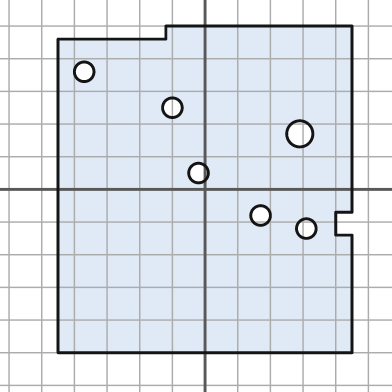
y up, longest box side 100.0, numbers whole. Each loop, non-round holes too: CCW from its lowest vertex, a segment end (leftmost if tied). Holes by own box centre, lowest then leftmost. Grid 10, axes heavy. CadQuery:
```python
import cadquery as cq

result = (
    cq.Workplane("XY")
    .moveTo(-45.0, -50.0)
    .lineTo(45.0, -50.0)
    .lineTo(45.0, -14.0)
    .lineTo(40.0, -14.0)
    .lineTo(40.0, -7.0)
    .lineTo(45.0, -7.0)
    .lineTo(45.0, 50.0)
    .lineTo(-12.0, 50.0)
    .lineTo(-12.0, 46.0)
    .lineTo(-45.0, 46.0)
    .close()
    .moveTo(31.0, -12.0)
    .circle(3.0)
    .moveTo(17.0, -8.0)
    .circle(3.0)
    .moveTo(-2.0, 5.0)
    .circle(3.0)
    .moveTo(29.0, 17.0)
    .circle(4.0)
    .moveTo(-10.0, 25.0)
    .circle(3.0)
    .moveTo(-37.0, 36.0)
    .circle(3.0)
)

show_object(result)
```